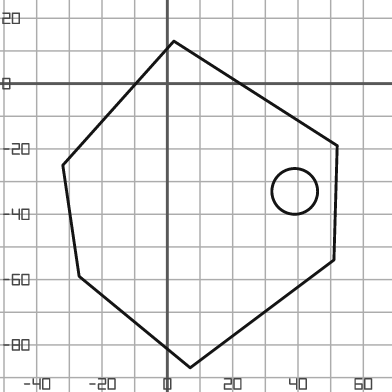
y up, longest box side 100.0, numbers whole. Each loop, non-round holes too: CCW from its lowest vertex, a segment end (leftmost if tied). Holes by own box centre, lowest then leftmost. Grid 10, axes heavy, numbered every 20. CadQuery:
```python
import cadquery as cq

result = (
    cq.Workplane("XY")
    .moveTo(7.0, -87.0)
    .lineTo(51.0, -54.0)
    .lineTo(52.0, -19.0)
    .lineTo(2.0, 13.0)
    .lineTo(-32.0, -25.0)
    .lineTo(-27.0, -59.0)
    .close()
    .moveTo(39.0, -33.0)
    .circle(7.0)
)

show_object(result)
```